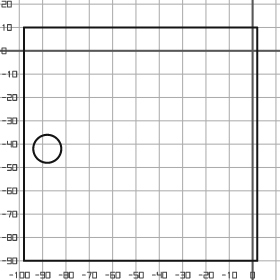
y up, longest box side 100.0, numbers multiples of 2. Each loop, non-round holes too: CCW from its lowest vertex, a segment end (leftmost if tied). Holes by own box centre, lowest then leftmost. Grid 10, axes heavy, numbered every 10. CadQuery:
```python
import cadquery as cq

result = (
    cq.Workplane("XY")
    .moveTo(-98.0, -90.0)
    .lineTo(2.0, -90.0)
    .lineTo(2.0, 10.0)
    .lineTo(-98.0, 10.0)
    .close()
    .moveTo(-88.0, -42.0)
    .circle(6.0)
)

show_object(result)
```